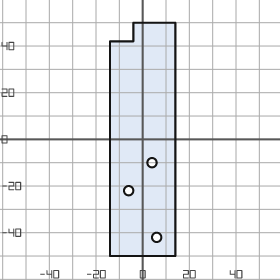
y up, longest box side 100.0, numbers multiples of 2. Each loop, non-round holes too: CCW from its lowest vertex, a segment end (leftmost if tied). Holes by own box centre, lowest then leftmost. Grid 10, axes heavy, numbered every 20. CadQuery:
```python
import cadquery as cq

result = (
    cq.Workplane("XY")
    .moveTo(-14.0, -50.0)
    .lineTo(14.0, -50.0)
    .lineTo(14.0, 50.0)
    .lineTo(-4.0, 50.0)
    .lineTo(-4.0, 42.0)
    .lineTo(-14.0, 42.0)
    .close()
    .moveTo(6.0, -42.0)
    .circle(2.0)
    .moveTo(-6.0, -22.0)
    .circle(2.0)
    .moveTo(4.0, -10.0)
    .circle(2.0)
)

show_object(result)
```